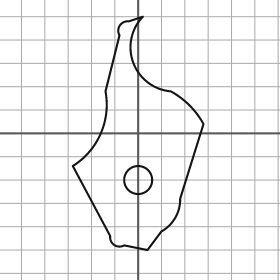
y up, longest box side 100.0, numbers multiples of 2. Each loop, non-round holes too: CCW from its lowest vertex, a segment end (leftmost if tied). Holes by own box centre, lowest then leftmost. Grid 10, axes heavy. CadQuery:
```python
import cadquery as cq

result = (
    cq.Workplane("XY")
    .moveTo(4.0, -50.0)
    .lineTo(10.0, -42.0)
    .threePointArc((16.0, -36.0), (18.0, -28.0))
    .lineTo(28.0, 4.0)
    .threePointArc((22.0, 12.0), (14.0, 18.0))
    .threePointArc((-2.0, 30.0), (2.0, 50.0))
    .lineTo(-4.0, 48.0)
    .threePointArc((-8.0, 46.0), (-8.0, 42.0))
    .lineTo(-14.0, 18.0)
    .threePointArc((-16.0, 0.0), (-28.0, -14.0))
    .lineTo(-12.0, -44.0)
    .threePointArc((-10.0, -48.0), (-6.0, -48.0))
    .close()
    .moveTo(0.0, -20.0)
    .circle(6.0)
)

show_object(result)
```